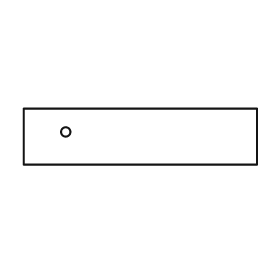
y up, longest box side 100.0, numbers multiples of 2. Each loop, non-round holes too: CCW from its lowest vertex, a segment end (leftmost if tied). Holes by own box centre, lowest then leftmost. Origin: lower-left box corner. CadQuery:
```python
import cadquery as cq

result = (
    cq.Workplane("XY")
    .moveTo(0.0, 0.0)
    .lineTo(100.0, 0.0)
    .lineTo(100.0, 24.0)
    .lineTo(0.0, 24.0)
    .close()
    .moveTo(18.0, 14.0)
    .circle(2.0)
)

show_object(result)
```